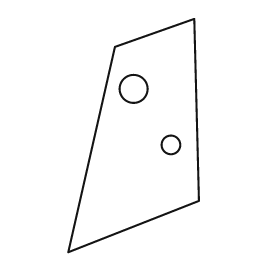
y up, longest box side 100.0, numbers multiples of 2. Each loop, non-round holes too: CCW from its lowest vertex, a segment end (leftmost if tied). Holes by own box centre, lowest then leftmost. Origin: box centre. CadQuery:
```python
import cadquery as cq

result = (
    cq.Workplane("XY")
    .moveTo(-28.0, -50.0)
    .lineTo(28.0, -28.0)
    .lineTo(26.0, 50.0)
    .lineTo(-8.0, 38.0)
    .close()
    .moveTo(16.0, -4.0)
    .circle(4.0)
    .moveTo(0.0, 20.0)
    .circle(6.0)
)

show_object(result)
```